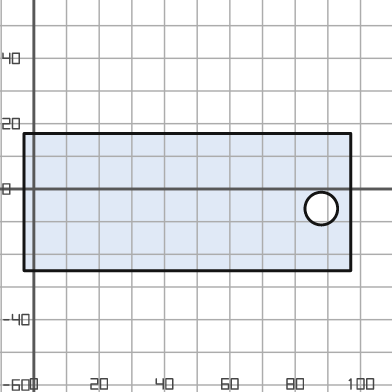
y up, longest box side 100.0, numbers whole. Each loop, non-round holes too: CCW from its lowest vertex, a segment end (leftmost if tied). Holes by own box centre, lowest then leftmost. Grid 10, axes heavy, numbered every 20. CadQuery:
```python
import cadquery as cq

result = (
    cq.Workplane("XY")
    .moveTo(-3.0, -25.0)
    .lineTo(97.0, -25.0)
    .lineTo(97.0, 17.0)
    .lineTo(-3.0, 17.0)
    .close()
    .moveTo(88.0, -6.0)
    .circle(5.0)
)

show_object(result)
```